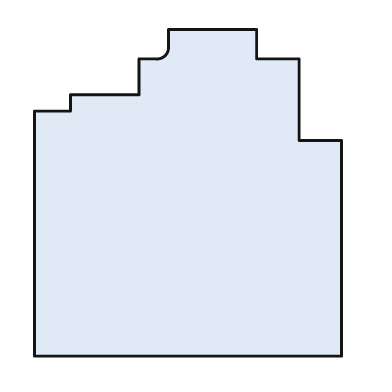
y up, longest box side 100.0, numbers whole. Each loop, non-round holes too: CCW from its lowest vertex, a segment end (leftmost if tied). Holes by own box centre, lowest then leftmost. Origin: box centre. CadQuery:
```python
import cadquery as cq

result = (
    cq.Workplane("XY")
    .moveTo(-47.0, -50.0)
    .lineTo(47.0, -50.0)
    .lineTo(47.0, 16.0)
    .lineTo(34.0, 16.0)
    .lineTo(34.0, 41.0)
    .lineTo(21.0, 41.0)
    .lineTo(21.0, 50.0)
    .lineTo(-6.0, 50.0)
    .lineTo(-6.0, 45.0)
    .threePointArc((-7.0, 42.0), (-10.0, 41.0))
    .lineTo(-15.0, 41.0)
    .lineTo(-15.0, 30.0)
    .lineTo(-36.0, 30.0)
    .lineTo(-36.0, 25.0)
    .lineTo(-47.0, 25.0)
    .close()
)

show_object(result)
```